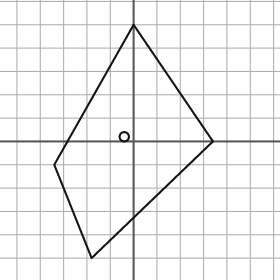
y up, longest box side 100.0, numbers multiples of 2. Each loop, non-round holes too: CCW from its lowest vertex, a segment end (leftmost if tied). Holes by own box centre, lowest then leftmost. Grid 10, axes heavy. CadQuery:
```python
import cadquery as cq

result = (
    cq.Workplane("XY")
    .moveTo(-18.0, -50.0)
    .lineTo(34.0, 0.0)
    .lineTo(0.0, 50.0)
    .lineTo(-34.0, -10.0)
    .close()
    .moveTo(-4.0, 2.0)
    .circle(2.0)
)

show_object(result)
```